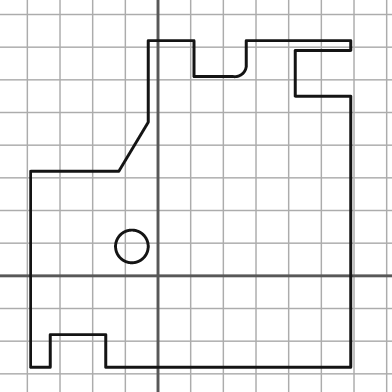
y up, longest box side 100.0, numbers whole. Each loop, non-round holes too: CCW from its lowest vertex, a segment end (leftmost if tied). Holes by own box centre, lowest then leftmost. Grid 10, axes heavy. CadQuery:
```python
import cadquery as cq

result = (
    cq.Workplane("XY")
    .moveTo(-39.0, -28.0)
    .lineTo(-33.0, -28.0)
    .lineTo(-33.0, -18.0)
    .lineTo(-16.0, -18.0)
    .lineTo(-16.0, -28.0)
    .lineTo(59.0, -28.0)
    .lineTo(59.0, 55.0)
    .lineTo(42.0, 55.0)
    .lineTo(42.0, 69.0)
    .lineTo(59.0, 69.0)
    .lineTo(59.0, 72.0)
    .lineTo(27.0, 72.0)
    .lineTo(27.0, 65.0)
    .threePointArc((26.0, 62.0), (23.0, 61.0))
    .lineTo(11.0, 61.0)
    .lineTo(11.0, 72.0)
    .lineTo(-3.0, 72.0)
    .lineTo(-3.0, 47.0)
    .lineTo(-12.0, 32.0)
    .lineTo(-39.0, 32.0)
    .close()
    .moveTo(-8.0, 9.0)
    .circle(5.0)
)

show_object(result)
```